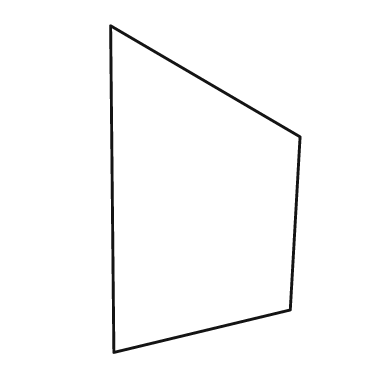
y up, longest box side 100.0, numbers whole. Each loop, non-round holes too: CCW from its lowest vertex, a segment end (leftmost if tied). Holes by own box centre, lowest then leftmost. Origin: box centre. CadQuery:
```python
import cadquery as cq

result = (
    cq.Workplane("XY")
    .moveTo(-28.0, -50.0)
    .lineTo(26.0, -37.0)
    .lineTo(29.0, 16.0)
    .lineTo(-29.0, 50.0)
    .close()
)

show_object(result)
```